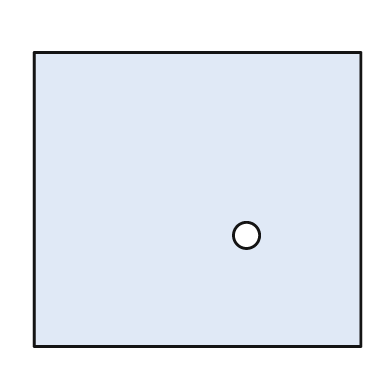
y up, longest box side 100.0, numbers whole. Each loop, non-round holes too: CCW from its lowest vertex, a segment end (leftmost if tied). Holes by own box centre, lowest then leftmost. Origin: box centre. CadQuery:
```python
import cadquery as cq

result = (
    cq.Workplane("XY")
    .moveTo(-50.0, -45.0)
    .lineTo(50.0, -45.0)
    .lineTo(50.0, 45.0)
    .lineTo(-50.0, 45.0)
    .close()
    .moveTo(15.0, -11.0)
    .circle(4.0)
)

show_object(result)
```